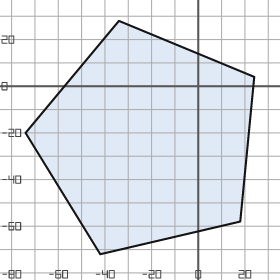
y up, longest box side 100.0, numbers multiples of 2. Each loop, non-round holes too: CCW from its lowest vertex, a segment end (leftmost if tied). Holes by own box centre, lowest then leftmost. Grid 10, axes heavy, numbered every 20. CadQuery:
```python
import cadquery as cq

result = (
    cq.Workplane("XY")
    .moveTo(-42.0, -72.0)
    .lineTo(18.0, -58.0)
    .lineTo(24.0, 4.0)
    .lineTo(-34.0, 28.0)
    .lineTo(-74.0, -20.0)
    .close()
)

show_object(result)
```